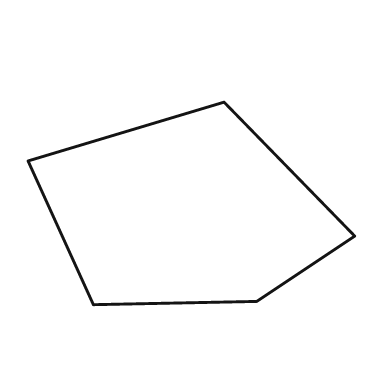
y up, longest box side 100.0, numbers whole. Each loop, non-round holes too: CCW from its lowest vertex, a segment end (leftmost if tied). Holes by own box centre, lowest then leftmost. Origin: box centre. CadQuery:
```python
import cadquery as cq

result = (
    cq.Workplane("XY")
    .moveTo(-30.0, -31.0)
    .lineTo(20.0, -30.0)
    .lineTo(50.0, -10.0)
    .lineTo(10.0, 31.0)
    .lineTo(-50.0, 13.0)
    .close()
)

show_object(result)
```